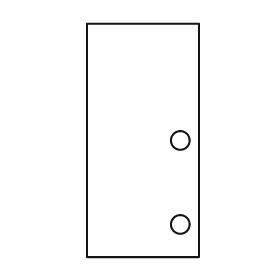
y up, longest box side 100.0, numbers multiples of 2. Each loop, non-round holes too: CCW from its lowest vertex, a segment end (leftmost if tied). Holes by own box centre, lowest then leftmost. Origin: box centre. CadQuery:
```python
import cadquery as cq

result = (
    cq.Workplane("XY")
    .moveTo(-24.0, -50.0)
    .lineTo(24.0, -50.0)
    .lineTo(24.0, 50.0)
    .lineTo(-24.0, 50.0)
    .close()
    .moveTo(16.0, -36.0)
    .circle(4.0)
    .moveTo(16.0, 0.0)
    .circle(4.0)
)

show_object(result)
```